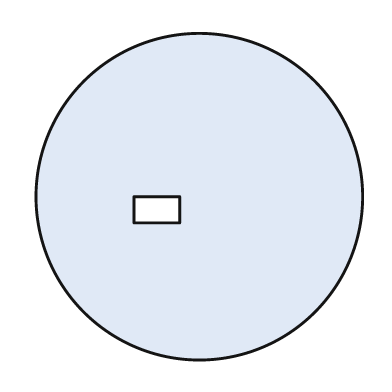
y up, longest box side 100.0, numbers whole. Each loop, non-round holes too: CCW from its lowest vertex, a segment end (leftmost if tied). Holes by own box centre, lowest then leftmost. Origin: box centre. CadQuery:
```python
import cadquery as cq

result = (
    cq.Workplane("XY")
    .moveTo(0.0, 0.0)
    .circle(50.0)
    .moveTo(-20.0, -8.0)
    .lineTo(-6.0, -8.0)
    .lineTo(-6.0, 0.0)
    .lineTo(-20.0, 0.0)
    .close()
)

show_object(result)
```